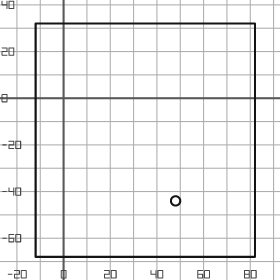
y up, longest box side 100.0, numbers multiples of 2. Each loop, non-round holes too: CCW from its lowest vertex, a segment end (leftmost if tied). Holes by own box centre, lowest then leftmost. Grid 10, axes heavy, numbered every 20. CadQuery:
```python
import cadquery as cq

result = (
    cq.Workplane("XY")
    .moveTo(-12.0, -68.0)
    .lineTo(82.0, -68.0)
    .lineTo(82.0, 32.0)
    .lineTo(-12.0, 32.0)
    .close()
    .moveTo(48.0, -44.0)
    .circle(2.0)
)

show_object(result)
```